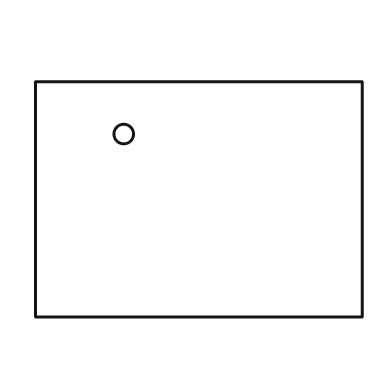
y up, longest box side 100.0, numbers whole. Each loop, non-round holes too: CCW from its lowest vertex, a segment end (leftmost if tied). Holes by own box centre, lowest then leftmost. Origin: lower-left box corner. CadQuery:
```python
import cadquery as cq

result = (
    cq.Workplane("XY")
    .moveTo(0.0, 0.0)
    .lineTo(100.0, 0.0)
    .lineTo(100.0, 72.0)
    .lineTo(0.0, 72.0)
    .close()
    .moveTo(27.0, 56.0)
    .circle(3.0)
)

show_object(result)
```